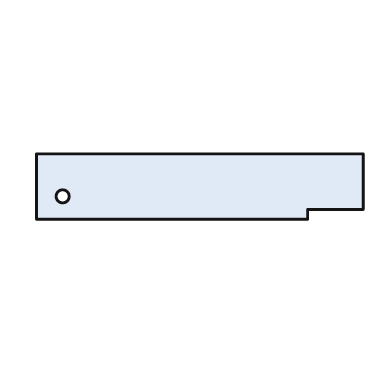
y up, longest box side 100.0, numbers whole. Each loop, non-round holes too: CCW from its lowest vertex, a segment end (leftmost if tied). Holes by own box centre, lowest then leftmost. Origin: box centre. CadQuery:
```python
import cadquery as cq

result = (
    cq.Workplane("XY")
    .moveTo(-50.0, -10.0)
    .lineTo(33.0, -10.0)
    .lineTo(33.0, -7.0)
    .lineTo(50.0, -7.0)
    .lineTo(50.0, 10.0)
    .lineTo(-50.0, 10.0)
    .close()
    .moveTo(-42.0, -3.0)
    .circle(2.0)
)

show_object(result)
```